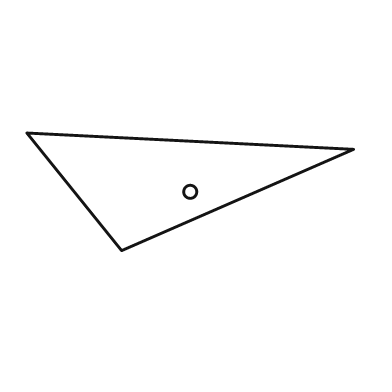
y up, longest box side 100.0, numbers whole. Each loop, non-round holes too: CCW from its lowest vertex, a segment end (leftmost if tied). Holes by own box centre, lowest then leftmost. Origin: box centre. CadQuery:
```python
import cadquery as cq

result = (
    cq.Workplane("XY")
    .moveTo(-21.0, -18.0)
    .lineTo(50.0, 13.0)
    .lineTo(-50.0, 18.0)
    .close()
    .moveTo(0.0, 0.0)
    .circle(2.0)
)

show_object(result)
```